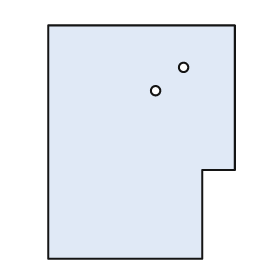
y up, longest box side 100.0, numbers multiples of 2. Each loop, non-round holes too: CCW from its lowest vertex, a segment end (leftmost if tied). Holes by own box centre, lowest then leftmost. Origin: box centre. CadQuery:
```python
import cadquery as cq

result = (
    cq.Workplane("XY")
    .moveTo(-40.0, -50.0)
    .lineTo(26.0, -50.0)
    .lineTo(26.0, -12.0)
    .lineTo(40.0, -12.0)
    .lineTo(40.0, 50.0)
    .lineTo(-40.0, 50.0)
    .close()
    .moveTo(6.0, 22.0)
    .circle(2.0)
    .moveTo(18.0, 32.0)
    .circle(2.0)
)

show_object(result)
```